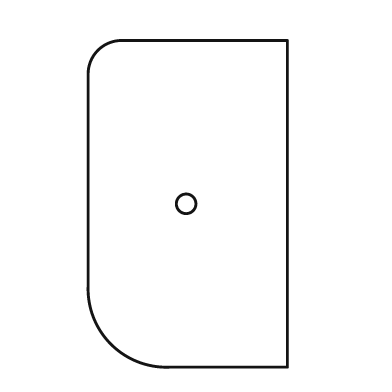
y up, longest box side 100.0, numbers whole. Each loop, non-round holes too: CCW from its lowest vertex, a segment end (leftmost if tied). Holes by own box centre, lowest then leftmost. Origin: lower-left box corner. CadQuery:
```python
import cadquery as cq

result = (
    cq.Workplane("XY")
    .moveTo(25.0, 0.0)
    .lineTo(61.0, 0.0)
    .lineTo(61.0, 100.0)
    .lineTo(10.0, 100.0)
    .threePointArc((3.0, 97.0), (0.0, 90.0))
    .lineTo(0.0, 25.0)
    .threePointArc((7.0, 7.0), (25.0, 0.0))
    .close()
    .moveTo(30.0, 50.0)
    .circle(3.0)
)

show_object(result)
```